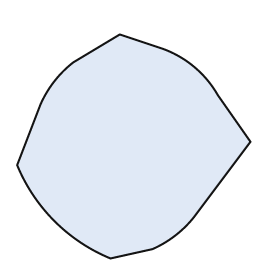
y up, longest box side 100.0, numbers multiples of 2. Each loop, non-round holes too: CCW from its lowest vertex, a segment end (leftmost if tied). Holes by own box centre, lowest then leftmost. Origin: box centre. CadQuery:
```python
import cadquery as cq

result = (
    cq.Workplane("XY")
    .moveTo(-10.0, -48.0)
    .lineTo(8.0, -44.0)
    .threePointArc((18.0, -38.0), (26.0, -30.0))
    .lineTo(50.0, 2.0)
    .lineTo(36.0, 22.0)
    .threePointArc((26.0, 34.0), (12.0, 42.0))
    .lineTo(-6.0, 48.0)
    .lineTo(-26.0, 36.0)
    .threePointArc((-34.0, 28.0), (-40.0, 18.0))
    .lineTo(-50.0, -8.0)
    .threePointArc((-34.0, -32.0), (-10.0, -48.0))
    .close()
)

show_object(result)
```